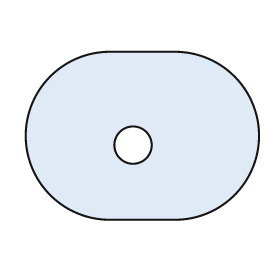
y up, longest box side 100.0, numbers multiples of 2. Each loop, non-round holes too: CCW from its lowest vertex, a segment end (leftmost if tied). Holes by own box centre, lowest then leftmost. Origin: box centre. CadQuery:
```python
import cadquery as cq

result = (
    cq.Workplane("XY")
    .moveTo(-14.0, -36.0)
    .lineTo(14.0, -36.0)
    .threePointArc((50.0, 0.0), (14.0, 36.0))
    .lineTo(-14.0, 36.0)
    .threePointArc((-50.0, 0.0), (-14.0, -36.0))
    .close()
    .moveTo(-4.0, -4.0)
    .circle(8.0)
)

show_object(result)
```